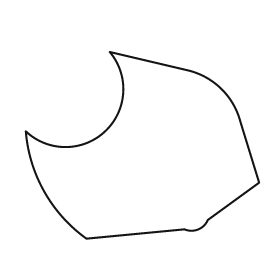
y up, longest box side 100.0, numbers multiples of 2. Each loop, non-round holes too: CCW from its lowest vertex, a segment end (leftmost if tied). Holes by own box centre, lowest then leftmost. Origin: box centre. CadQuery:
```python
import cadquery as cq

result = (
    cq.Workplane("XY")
    .moveTo(-24.0, -40.0)
    .lineTo(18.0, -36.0)
    .threePointArc((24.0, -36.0), (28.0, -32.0))
    .lineTo(50.0, -16.0)
    .lineTo(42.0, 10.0)
    .threePointArc((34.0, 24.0), (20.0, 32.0))
    .lineTo(-14.0, 40.0)
    .threePointArc((-16.0, 6.0), (-50.0, 6.0))
    .threePointArc((-42.0, -20.0), (-24.0, -40.0))
    .close()
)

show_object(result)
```